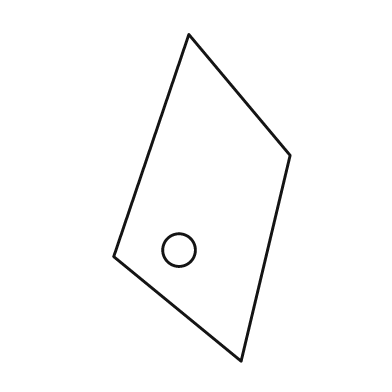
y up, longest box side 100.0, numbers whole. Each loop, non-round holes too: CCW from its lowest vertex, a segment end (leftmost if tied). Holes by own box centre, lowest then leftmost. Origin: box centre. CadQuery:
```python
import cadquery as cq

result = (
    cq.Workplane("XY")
    .moveTo(12.0, -50.0)
    .lineTo(27.0, 13.0)
    .lineTo(-4.0, 50.0)
    .lineTo(-27.0, -18.0)
    .close()
    .moveTo(-7.0, -16.0)
    .circle(5.0)
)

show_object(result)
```